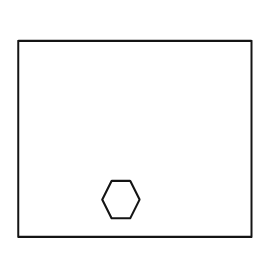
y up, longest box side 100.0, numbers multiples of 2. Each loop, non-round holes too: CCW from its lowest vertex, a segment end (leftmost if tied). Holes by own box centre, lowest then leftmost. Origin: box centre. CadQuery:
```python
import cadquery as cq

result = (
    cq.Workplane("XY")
    .moveTo(-50.0, -42.0)
    .lineTo(50.0, -42.0)
    .lineTo(50.0, 42.0)
    .lineTo(-50.0, 42.0)
    .close()
    .moveTo(-10.0, -34.0)
    .lineTo(-2.0, -34.0)
    .lineTo(2.0, -26.0)
    .lineTo(-2.0, -18.0)
    .lineTo(-10.0, -18.0)
    .lineTo(-14.0, -26.0)
    .close()
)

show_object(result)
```